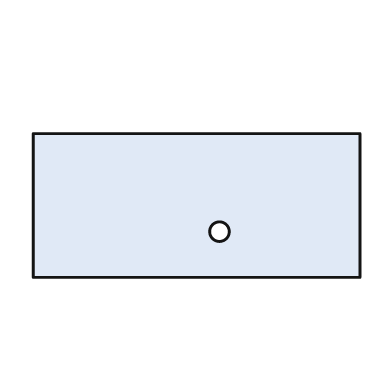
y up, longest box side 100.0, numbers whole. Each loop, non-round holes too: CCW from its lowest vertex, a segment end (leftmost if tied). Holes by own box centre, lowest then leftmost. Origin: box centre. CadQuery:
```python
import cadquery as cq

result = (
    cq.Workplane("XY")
    .moveTo(-50.0, -22.0)
    .lineTo(50.0, -22.0)
    .lineTo(50.0, 22.0)
    .lineTo(-50.0, 22.0)
    .close()
    .moveTo(7.0, -8.0)
    .circle(3.0)
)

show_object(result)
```